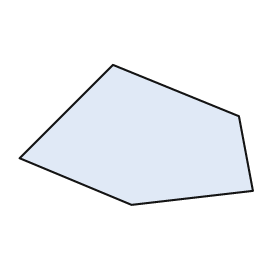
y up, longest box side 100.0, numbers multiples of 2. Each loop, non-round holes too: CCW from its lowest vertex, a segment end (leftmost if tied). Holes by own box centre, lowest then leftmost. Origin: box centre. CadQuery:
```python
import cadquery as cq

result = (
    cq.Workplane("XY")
    .moveTo(-2.0, -30.0)
    .lineTo(50.0, -24.0)
    .lineTo(44.0, 8.0)
    .lineTo(-10.0, 30.0)
    .lineTo(-50.0, -10.0)
    .close()
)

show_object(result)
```